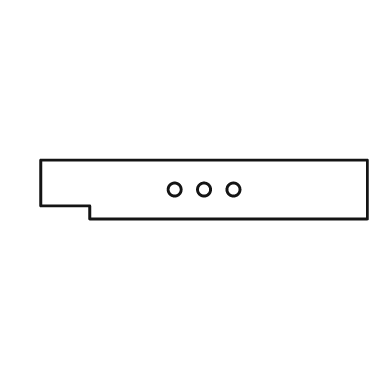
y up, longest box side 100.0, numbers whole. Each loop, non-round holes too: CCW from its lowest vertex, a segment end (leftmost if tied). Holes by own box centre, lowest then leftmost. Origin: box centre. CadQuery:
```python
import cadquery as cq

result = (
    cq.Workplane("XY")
    .moveTo(-35.0, -9.0)
    .lineTo(50.0, -9.0)
    .lineTo(50.0, 9.0)
    .lineTo(-50.0, 9.0)
    .lineTo(-50.0, -5.0)
    .lineTo(-35.0, -5.0)
    .close()
    .moveTo(-9.0, 0.0)
    .circle(2.0)
    .moveTo(0.0, 0.0)
    .circle(2.0)
    .moveTo(9.0, 0.0)
    .circle(2.0)
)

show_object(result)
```